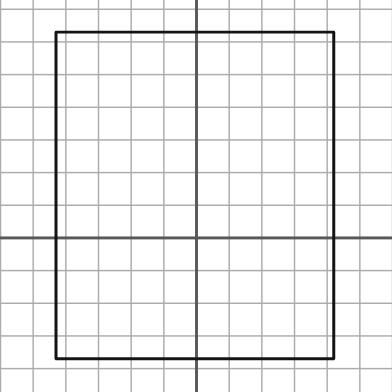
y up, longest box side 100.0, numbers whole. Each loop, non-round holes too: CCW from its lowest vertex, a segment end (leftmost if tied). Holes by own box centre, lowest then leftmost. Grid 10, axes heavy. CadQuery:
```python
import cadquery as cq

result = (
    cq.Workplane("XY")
    .moveTo(-43.0, -37.0)
    .lineTo(42.0, -37.0)
    .lineTo(42.0, 63.0)
    .lineTo(-43.0, 63.0)
    .close()
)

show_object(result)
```